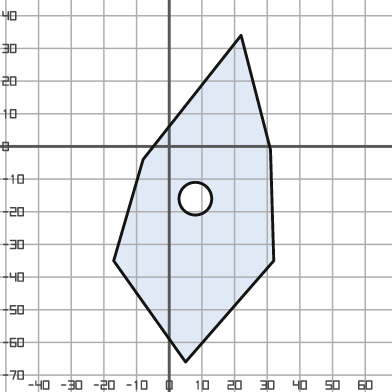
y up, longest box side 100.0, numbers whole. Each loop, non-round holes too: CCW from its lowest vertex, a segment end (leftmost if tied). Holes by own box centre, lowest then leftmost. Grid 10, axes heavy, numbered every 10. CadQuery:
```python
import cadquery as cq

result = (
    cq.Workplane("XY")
    .moveTo(5.0, -66.0)
    .lineTo(32.0, -35.0)
    .lineTo(31.0, -1.0)
    .lineTo(22.0, 34.0)
    .lineTo(-8.0, -4.0)
    .lineTo(-17.0, -35.0)
    .close()
    .moveTo(8.0, -16.0)
    .circle(5.0)
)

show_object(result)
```